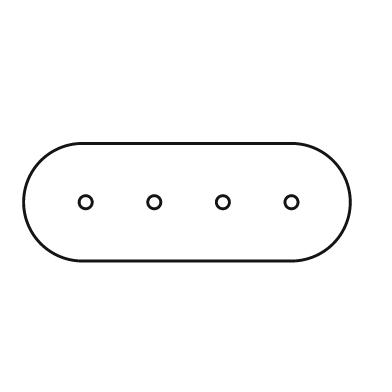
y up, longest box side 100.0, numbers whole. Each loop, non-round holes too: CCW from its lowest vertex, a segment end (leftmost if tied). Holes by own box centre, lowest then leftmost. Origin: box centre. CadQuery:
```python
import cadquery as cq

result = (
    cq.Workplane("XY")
    .moveTo(-32.0, -18.0)
    .lineTo(32.0, -18.0)
    .threePointArc((50.0, 0.0), (32.0, 18.0))
    .lineTo(-32.0, 18.0)
    .threePointArc((-50.0, 0.0), (-32.0, -18.0))
    .close()
    .moveTo(-31.0, 0.0)
    .circle(2.0)
    .moveTo(-10.0, 0.0)
    .circle(2.0)
    .moveTo(11.0, 0.0)
    .circle(2.0)
    .moveTo(32.0, 0.0)
    .circle(2.0)
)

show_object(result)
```